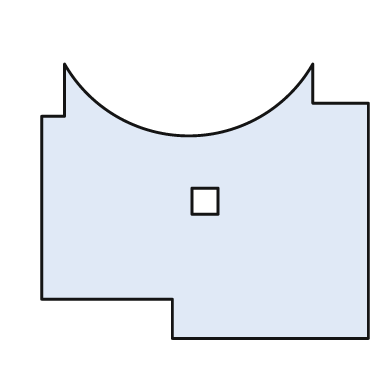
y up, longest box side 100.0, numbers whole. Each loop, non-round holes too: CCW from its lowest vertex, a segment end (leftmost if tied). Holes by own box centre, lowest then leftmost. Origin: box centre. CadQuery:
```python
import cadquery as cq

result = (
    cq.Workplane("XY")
    .moveTo(-10.0, -42.0)
    .lineTo(50.0, -42.0)
    .lineTo(50.0, 30.0)
    .lineTo(33.0, 30.0)
    .lineTo(33.0, 42.0)
    .threePointArc((-5.0, 20.0), (-43.0, 42.0))
    .lineTo(-43.0, 26.0)
    .lineTo(-50.0, 26.0)
    .lineTo(-50.0, -30.0)
    .lineTo(-10.0, -30.0)
    .close()
    .moveTo(-4.0, -4.0)
    .lineTo(4.0, -4.0)
    .lineTo(4.0, 4.0)
    .lineTo(-4.0, 4.0)
    .close()
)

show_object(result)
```